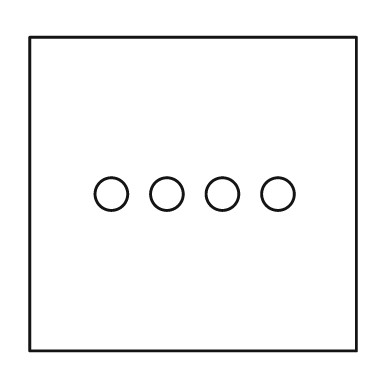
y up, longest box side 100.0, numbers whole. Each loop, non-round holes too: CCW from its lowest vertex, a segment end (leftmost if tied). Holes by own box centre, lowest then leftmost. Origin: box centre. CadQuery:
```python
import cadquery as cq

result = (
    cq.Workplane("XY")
    .moveTo(-50.0, -48.0)
    .lineTo(50.0, -48.0)
    .lineTo(50.0, 48.0)
    .lineTo(-50.0, 48.0)
    .close()
    .moveTo(-25.0, 0.0)
    .circle(5.0)
    .moveTo(-8.0, 0.0)
    .circle(5.0)
    .moveTo(9.0, 0.0)
    .circle(5.0)
    .moveTo(26.0, 0.0)
    .circle(5.0)
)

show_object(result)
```